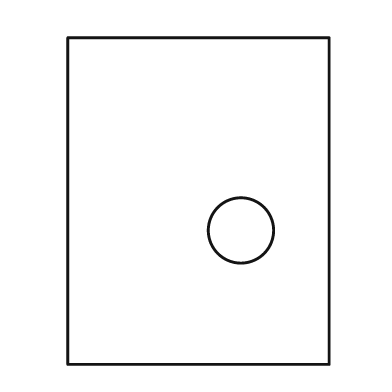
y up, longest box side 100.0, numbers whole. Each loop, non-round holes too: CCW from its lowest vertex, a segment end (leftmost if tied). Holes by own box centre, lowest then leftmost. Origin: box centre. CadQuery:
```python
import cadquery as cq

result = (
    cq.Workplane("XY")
    .moveTo(-40.0, -50.0)
    .lineTo(40.0, -50.0)
    .lineTo(40.0, 50.0)
    .lineTo(-40.0, 50.0)
    .close()
    .moveTo(13.0, -9.0)
    .circle(10.0)
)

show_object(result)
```